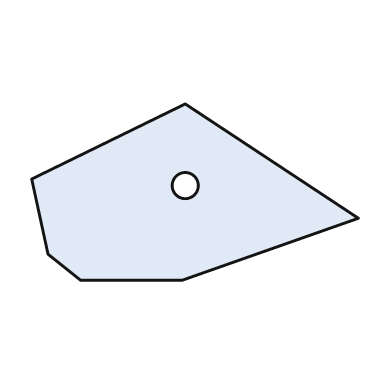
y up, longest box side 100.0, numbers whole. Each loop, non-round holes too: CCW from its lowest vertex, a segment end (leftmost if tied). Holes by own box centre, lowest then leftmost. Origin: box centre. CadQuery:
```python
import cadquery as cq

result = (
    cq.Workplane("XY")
    .moveTo(-35.0, -27.0)
    .lineTo(-4.0, -27.0)
    .lineTo(50.0, -8.0)
    .lineTo(-3.0, 27.0)
    .lineTo(-50.0, 4.0)
    .lineTo(-45.0, -19.0)
    .close()
    .moveTo(-3.0, 2.0)
    .circle(4.0)
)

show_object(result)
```